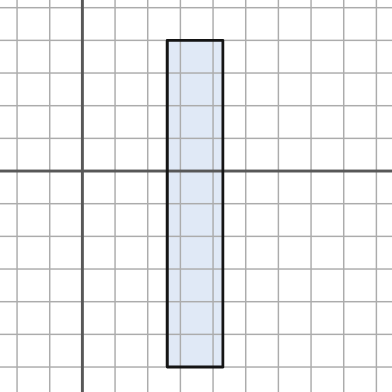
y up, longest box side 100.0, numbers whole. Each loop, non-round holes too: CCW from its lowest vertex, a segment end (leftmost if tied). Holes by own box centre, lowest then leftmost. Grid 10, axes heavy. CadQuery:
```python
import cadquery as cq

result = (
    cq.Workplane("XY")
    .moveTo(26.0, -60.0)
    .lineTo(43.0, -60.0)
    .lineTo(43.0, 40.0)
    .lineTo(26.0, 40.0)
    .close()
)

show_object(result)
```